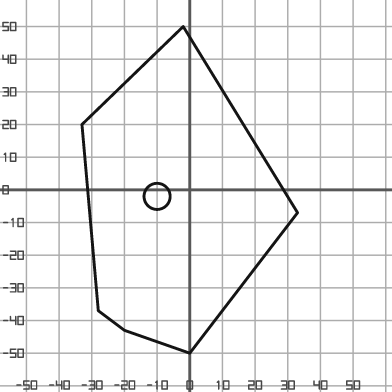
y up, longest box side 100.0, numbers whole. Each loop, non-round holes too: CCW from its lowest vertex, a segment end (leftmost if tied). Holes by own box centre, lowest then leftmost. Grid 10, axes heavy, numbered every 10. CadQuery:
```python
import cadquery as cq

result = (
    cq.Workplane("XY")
    .moveTo(0.0, -50.0)
    .lineTo(33.0, -7.0)
    .lineTo(-2.0, 50.0)
    .lineTo(-33.0, 20.0)
    .lineTo(-28.0, -37.0)
    .lineTo(-20.0, -43.0)
    .close()
    .moveTo(-10.0, -2.0)
    .circle(4.0)
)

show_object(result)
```